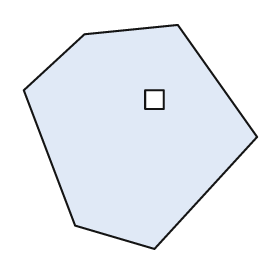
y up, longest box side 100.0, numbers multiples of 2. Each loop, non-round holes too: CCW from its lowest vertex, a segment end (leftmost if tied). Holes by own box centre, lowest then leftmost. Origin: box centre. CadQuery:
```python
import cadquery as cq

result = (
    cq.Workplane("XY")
    .moveTo(6.0, -48.0)
    .lineTo(50.0, 0.0)
    .lineTo(16.0, 48.0)
    .lineTo(-24.0, 44.0)
    .lineTo(-50.0, 20.0)
    .lineTo(-28.0, -38.0)
    .close()
    .moveTo(2.0, 12.0)
    .lineTo(10.0, 12.0)
    .lineTo(10.0, 20.0)
    .lineTo(2.0, 20.0)
    .close()
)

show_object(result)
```